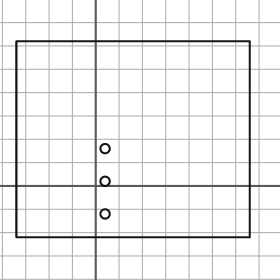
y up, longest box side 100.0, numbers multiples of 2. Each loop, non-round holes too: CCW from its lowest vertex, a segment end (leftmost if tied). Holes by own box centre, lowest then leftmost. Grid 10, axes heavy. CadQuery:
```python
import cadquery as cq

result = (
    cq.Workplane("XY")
    .moveTo(-34.0, -22.0)
    .lineTo(66.0, -22.0)
    .lineTo(66.0, 62.0)
    .lineTo(-34.0, 62.0)
    .close()
    .moveTo(4.0, -12.0)
    .circle(2.0)
    .moveTo(4.0, 2.0)
    .circle(2.0)
    .moveTo(4.0, 16.0)
    .circle(2.0)
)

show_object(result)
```